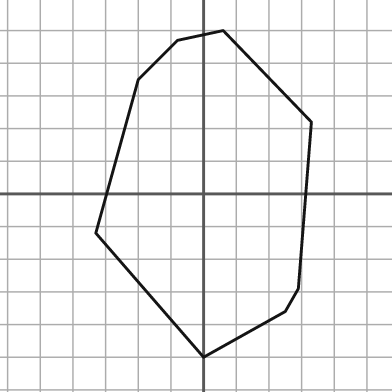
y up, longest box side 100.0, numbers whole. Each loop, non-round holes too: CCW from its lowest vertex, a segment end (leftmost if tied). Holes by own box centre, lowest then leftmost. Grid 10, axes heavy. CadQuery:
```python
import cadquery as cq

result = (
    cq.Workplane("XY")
    .moveTo(0.0, -50.0)
    .lineTo(25.0, -36.0)
    .lineTo(29.0, -29.0)
    .lineTo(33.0, 22.0)
    .lineTo(6.0, 50.0)
    .lineTo(-8.0, 47.0)
    .lineTo(-20.0, 35.0)
    .lineTo(-33.0, -12.0)
    .close()
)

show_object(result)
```